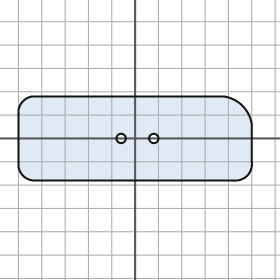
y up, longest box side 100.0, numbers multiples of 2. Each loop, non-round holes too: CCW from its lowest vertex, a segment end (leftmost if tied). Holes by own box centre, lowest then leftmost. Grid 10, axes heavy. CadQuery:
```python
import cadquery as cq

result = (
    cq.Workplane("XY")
    .moveTo(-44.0, -18.0)
    .lineTo(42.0, -18.0)
    .threePointArc((48.0, -16.0), (50.0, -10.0))
    .lineTo(50.0, 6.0)
    .threePointArc((46.0, 14.0), (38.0, 18.0))
    .lineTo(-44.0, 18.0)
    .threePointArc((-48.0, 16.0), (-50.0, 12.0))
    .lineTo(-50.0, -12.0)
    .threePointArc((-48.0, -16.0), (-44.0, -18.0))
    .close()
    .moveTo(-6.0, 0.0)
    .circle(2.0)
    .moveTo(8.0, 0.0)
    .circle(2.0)
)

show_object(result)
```